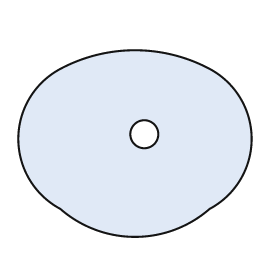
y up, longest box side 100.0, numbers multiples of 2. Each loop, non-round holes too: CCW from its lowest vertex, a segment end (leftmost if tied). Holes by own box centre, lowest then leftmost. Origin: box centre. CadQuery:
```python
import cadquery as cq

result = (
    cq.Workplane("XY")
    .moveTo(-32.0, -28.0)
    .threePointArc((0.0, -40.0), (32.0, -28.0))
    .threePointArc((50.0, 2.0), (32.0, 32.0))
    .threePointArc((0.0, 40.0), (-32.0, 32.0))
    .threePointArc((-50.0, 2.0), (-32.0, -28.0))
    .close()
    .moveTo(4.0, 4.0)
    .circle(6.0)
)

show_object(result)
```